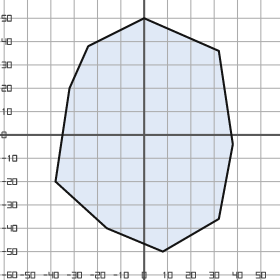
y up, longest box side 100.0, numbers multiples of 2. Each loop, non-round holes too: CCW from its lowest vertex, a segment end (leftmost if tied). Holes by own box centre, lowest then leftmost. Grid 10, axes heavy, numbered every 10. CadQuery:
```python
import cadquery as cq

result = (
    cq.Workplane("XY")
    .moveTo(8.0, -50.0)
    .lineTo(32.0, -36.0)
    .lineTo(38.0, -4.0)
    .lineTo(32.0, 36.0)
    .lineTo(0.0, 50.0)
    .lineTo(-24.0, 38.0)
    .lineTo(-32.0, 20.0)
    .lineTo(-38.0, -20.0)
    .lineTo(-16.0, -40.0)
    .close()
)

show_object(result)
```